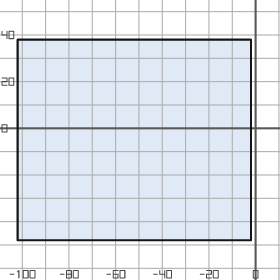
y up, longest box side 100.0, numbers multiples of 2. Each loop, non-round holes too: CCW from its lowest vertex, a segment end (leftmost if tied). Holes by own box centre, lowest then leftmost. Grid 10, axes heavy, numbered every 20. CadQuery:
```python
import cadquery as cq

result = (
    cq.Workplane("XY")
    .moveTo(-102.0, -48.0)
    .lineTo(-2.0, -48.0)
    .lineTo(-2.0, 38.0)
    .lineTo(-102.0, 38.0)
    .close()
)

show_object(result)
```